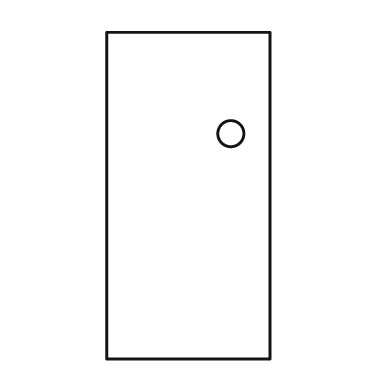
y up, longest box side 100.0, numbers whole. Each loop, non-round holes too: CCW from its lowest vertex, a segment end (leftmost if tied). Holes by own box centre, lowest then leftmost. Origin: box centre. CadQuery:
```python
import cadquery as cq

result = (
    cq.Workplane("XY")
    .moveTo(-25.0, -50.0)
    .lineTo(25.0, -50.0)
    .lineTo(25.0, 50.0)
    .lineTo(-25.0, 50.0)
    .close()
    .moveTo(13.0, 19.0)
    .circle(4.0)
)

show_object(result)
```